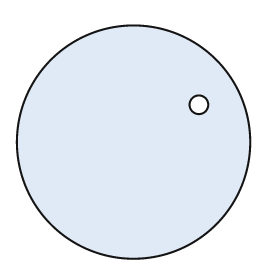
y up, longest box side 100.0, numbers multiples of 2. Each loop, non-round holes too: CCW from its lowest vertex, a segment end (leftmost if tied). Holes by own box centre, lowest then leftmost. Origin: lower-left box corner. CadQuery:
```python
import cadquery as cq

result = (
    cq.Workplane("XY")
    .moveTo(50.0, 50.0)
    .circle(50.0)
    .moveTo(78.0, 66.0)
    .circle(4.0)
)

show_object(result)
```